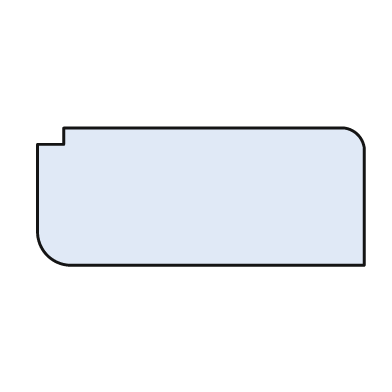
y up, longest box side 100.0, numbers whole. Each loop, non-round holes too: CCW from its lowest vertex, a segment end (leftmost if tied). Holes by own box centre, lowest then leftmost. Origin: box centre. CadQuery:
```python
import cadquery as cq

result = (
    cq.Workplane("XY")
    .moveTo(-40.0, -21.0)
    .lineTo(50.0, -21.0)
    .lineTo(50.0, 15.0)
    .threePointArc((48.0, 19.0), (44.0, 21.0))
    .lineTo(-42.0, 21.0)
    .lineTo(-42.0, 16.0)
    .lineTo(-50.0, 16.0)
    .lineTo(-50.0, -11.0)
    .threePointArc((-47.0, -18.0), (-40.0, -21.0))
    .close()
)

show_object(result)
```